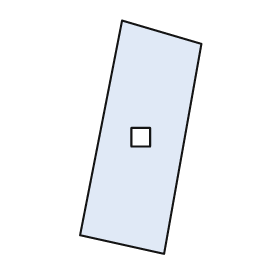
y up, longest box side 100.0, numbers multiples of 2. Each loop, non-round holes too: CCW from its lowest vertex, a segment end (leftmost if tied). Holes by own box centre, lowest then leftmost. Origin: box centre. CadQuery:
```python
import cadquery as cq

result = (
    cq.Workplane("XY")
    .moveTo(10.0, -50.0)
    .lineTo(26.0, 40.0)
    .lineTo(-8.0, 50.0)
    .lineTo(-26.0, -42.0)
    .close()
    .moveTo(-4.0, -4.0)
    .lineTo(4.0, -4.0)
    .lineTo(4.0, 4.0)
    .lineTo(-4.0, 4.0)
    .close()
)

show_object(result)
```